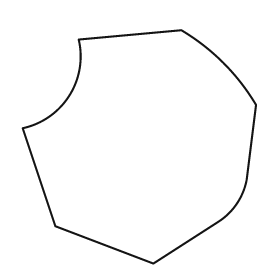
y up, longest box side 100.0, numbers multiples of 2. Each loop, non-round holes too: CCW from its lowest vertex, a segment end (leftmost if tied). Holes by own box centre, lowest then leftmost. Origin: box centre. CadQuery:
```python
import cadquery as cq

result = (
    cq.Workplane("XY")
    .moveTo(6.0, -50.0)
    .lineTo(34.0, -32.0)
    .threePointArc((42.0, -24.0), (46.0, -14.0))
    .lineTo(50.0, 18.0)
    .threePointArc((36.0, 36.0), (18.0, 50.0))
    .lineTo(-26.0, 46.0)
    .threePointArc((-30.0, 22.0), (-50.0, 8.0))
    .lineTo(-36.0, -34.0)
    .close()
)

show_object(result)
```